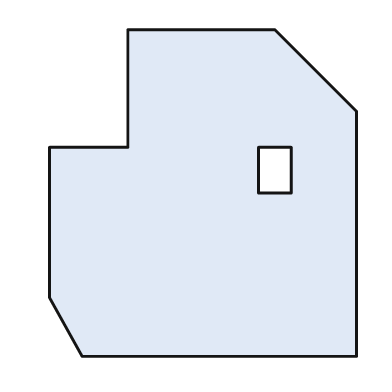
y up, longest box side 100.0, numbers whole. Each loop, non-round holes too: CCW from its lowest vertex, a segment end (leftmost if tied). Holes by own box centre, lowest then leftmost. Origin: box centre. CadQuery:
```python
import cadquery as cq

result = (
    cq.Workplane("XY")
    .moveTo(-37.0, -50.0)
    .lineTo(47.0, -50.0)
    .lineTo(47.0, 25.0)
    .lineTo(22.0, 50.0)
    .lineTo(-23.0, 50.0)
    .lineTo(-23.0, 14.0)
    .lineTo(-47.0, 14.0)
    .lineTo(-47.0, -32.0)
    .close()
    .moveTo(17.0, 0.0)
    .lineTo(27.0, 0.0)
    .lineTo(27.0, 14.0)
    .lineTo(17.0, 14.0)
    .close()
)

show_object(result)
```